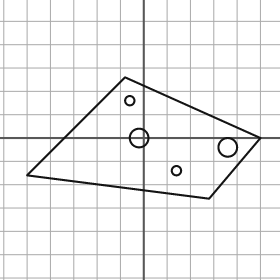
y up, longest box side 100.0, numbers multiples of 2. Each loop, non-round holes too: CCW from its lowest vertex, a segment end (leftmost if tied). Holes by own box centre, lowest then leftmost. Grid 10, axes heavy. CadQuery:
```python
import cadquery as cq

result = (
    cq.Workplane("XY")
    .moveTo(28.0, -26.0)
    .lineTo(50.0, 0.0)
    .lineTo(-8.0, 26.0)
    .lineTo(-50.0, -16.0)
    .close()
    .moveTo(14.0, -14.0)
    .circle(2.0)
    .moveTo(36.0, -4.0)
    .circle(4.0)
    .moveTo(-2.0, 0.0)
    .circle(4.0)
    .moveTo(-6.0, 16.0)
    .circle(2.0)
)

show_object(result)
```